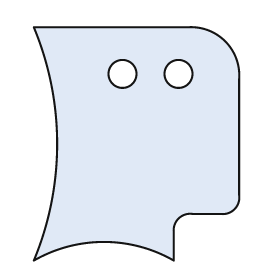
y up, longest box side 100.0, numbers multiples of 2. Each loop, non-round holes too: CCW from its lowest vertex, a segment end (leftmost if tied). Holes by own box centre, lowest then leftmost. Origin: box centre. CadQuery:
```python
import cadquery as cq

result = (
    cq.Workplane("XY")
    .moveTo(-44.0, -50.0)
    .threePointArc((-14.0, -42.0), (16.0, -50.0))
    .lineTo(16.0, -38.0)
    .threePointArc((18.0, -32.0), (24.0, -30.0))
    .lineTo(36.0, -30.0)
    .threePointArc((42.0, -28.0), (44.0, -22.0))
    .lineTo(44.0, 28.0)
    .threePointArc((38.0, 44.0), (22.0, 50.0))
    .lineTo(-44.0, 50.0)
    .threePointArc((-34.0, 0.0), (-44.0, -50.0))
    .close()
    .moveTo(-6.0, 30.0)
    .circle(6.0)
    .moveTo(18.0, 30.0)
    .circle(6.0)
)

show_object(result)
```